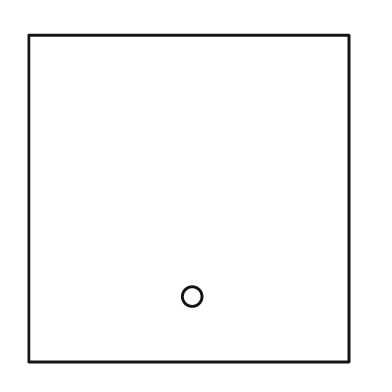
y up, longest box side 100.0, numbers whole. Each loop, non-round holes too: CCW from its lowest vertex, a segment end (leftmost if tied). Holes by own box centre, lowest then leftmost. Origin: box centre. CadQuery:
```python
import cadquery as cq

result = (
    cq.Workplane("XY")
    .moveTo(-49.0, -50.0)
    .lineTo(49.0, -50.0)
    .lineTo(49.0, 50.0)
    .lineTo(-49.0, 50.0)
    .close()
    .moveTo(1.0, -30.0)
    .circle(3.0)
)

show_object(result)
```